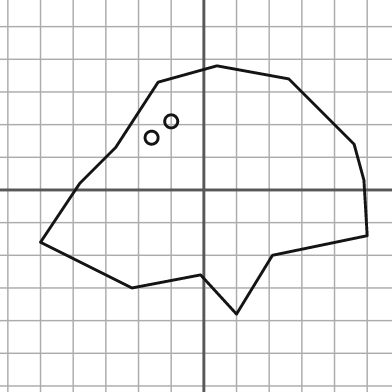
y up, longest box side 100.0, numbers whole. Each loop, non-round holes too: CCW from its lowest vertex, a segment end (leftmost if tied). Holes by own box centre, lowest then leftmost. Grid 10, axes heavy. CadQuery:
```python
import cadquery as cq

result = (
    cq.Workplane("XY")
    .moveTo(10.0, -38.0)
    .lineTo(21.0, -20.0)
    .lineTo(50.0, -14.0)
    .lineTo(49.0, 3.0)
    .lineTo(46.0, 14.0)
    .lineTo(26.0, 34.0)
    .lineTo(4.0, 38.0)
    .lineTo(-14.0, 33.0)
    .lineTo(-27.0, 13.0)
    .lineTo(-38.0, 2.0)
    .lineTo(-50.0, -16.0)
    .lineTo(-22.0, -30.0)
    .lineTo(-1.0, -26.0)
    .close()
    .moveTo(-16.0, 16.0)
    .circle(2.0)
    .moveTo(-10.0, 21.0)
    .circle(2.0)
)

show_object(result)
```